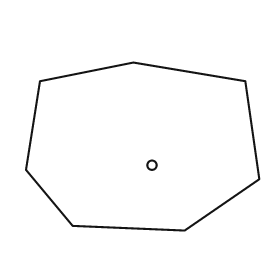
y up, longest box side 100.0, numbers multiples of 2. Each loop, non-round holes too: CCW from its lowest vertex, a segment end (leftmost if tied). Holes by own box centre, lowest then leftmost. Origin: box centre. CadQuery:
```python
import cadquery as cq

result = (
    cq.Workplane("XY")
    .moveTo(18.0, -36.0)
    .lineTo(50.0, -14.0)
    .lineTo(44.0, 28.0)
    .lineTo(-4.0, 36.0)
    .lineTo(-44.0, 28.0)
    .lineTo(-50.0, -10.0)
    .lineTo(-30.0, -34.0)
    .close()
    .moveTo(4.0, -8.0)
    .circle(2.0)
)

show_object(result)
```